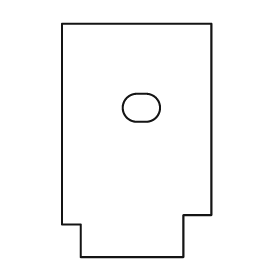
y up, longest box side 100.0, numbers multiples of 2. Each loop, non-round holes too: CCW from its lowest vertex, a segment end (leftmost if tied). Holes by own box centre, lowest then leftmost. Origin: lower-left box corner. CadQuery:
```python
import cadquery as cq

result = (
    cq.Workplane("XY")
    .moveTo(8.0, 0.0)
    .lineTo(52.0, 0.0)
    .lineTo(52.0, 18.0)
    .lineTo(64.0, 18.0)
    .lineTo(64.0, 100.0)
    .lineTo(0.0, 100.0)
    .lineTo(0.0, 14.0)
    .lineTo(8.0, 14.0)
    .close()
    .moveTo(32.0, 58.0)
    .lineTo(36.0, 58.0)
    .threePointArc((42.0, 64.0), (36.0, 70.0))
    .lineTo(32.0, 70.0)
    .threePointArc((26.0, 64.0), (32.0, 58.0))
    .close()
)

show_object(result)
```